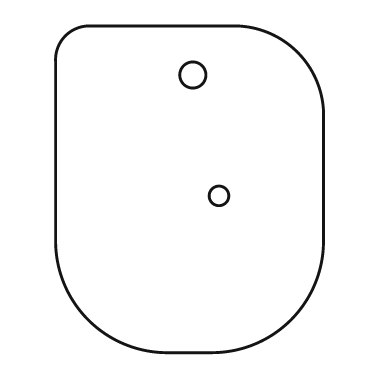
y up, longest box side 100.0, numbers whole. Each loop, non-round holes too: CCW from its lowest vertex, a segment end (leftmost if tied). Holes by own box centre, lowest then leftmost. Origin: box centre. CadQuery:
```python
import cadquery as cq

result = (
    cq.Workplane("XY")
    .moveTo(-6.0, -50.0)
    .lineTo(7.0, -50.0)
    .threePointArc((31.0, -40.0), (41.0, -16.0))
    .lineTo(41.0, 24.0)
    .threePointArc((33.0, 42.0), (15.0, 50.0))
    .lineTo(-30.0, 50.0)
    .threePointArc((-38.0, 47.0), (-41.0, 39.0))
    .lineTo(-41.0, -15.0)
    .threePointArc((-31.0, -40.0), (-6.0, -50.0))
    .close()
    .moveTo(9.0, -2.0)
    .circle(3.0)
    .moveTo(1.0, 35.0)
    .circle(4.0)
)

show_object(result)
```